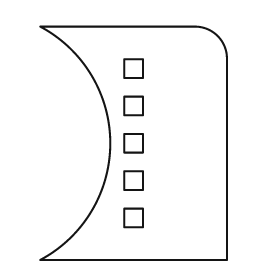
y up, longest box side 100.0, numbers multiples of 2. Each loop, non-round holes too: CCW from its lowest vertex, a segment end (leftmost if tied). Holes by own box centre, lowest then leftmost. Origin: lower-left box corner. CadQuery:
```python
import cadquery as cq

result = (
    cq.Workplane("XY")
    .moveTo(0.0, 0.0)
    .lineTo(80.0, 0.0)
    .lineTo(80.0, 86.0)
    .threePointArc((76.0, 96.0), (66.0, 100.0))
    .lineTo(0.0, 100.0)
    .threePointArc((30.0, 50.0), (0.0, 0.0))
    .close()
    .moveTo(36.0, 14.0)
    .lineTo(44.0, 14.0)
    .lineTo(44.0, 22.0)
    .lineTo(36.0, 22.0)
    .close()
    .moveTo(36.0, 30.0)
    .lineTo(44.0, 30.0)
    .lineTo(44.0, 38.0)
    .lineTo(36.0, 38.0)
    .close()
    .moveTo(36.0, 46.0)
    .lineTo(44.0, 46.0)
    .lineTo(44.0, 54.0)
    .lineTo(36.0, 54.0)
    .close()
    .moveTo(36.0, 62.0)
    .lineTo(44.0, 62.0)
    .lineTo(44.0, 70.0)
    .lineTo(36.0, 70.0)
    .close()
    .moveTo(36.0, 78.0)
    .lineTo(44.0, 78.0)
    .lineTo(44.0, 86.0)
    .lineTo(36.0, 86.0)
    .close()
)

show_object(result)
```